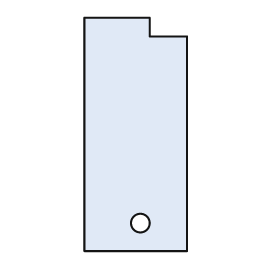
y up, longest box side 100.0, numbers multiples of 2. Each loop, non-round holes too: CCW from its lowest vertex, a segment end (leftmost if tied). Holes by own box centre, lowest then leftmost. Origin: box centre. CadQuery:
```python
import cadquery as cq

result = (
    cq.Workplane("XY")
    .moveTo(-22.0, -50.0)
    .lineTo(22.0, -50.0)
    .lineTo(22.0, 42.0)
    .lineTo(6.0, 42.0)
    .lineTo(6.0, 50.0)
    .lineTo(-22.0, 50.0)
    .close()
    .moveTo(2.0, -38.0)
    .circle(4.0)
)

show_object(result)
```